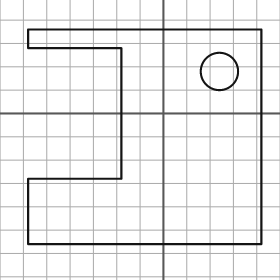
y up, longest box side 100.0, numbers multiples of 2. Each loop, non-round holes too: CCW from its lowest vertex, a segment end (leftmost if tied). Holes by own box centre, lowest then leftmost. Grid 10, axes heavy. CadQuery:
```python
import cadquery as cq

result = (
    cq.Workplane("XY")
    .moveTo(-58.0, -56.0)
    .lineTo(42.0, -56.0)
    .lineTo(42.0, 36.0)
    .lineTo(-58.0, 36.0)
    .lineTo(-58.0, 28.0)
    .lineTo(-18.0, 28.0)
    .lineTo(-18.0, -28.0)
    .lineTo(-58.0, -28.0)
    .close()
    .moveTo(24.0, 18.0)
    .circle(8.0)
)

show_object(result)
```